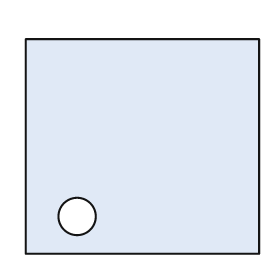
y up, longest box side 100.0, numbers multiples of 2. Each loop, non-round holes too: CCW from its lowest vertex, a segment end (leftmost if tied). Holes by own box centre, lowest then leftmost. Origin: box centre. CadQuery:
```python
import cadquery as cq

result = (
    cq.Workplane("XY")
    .moveTo(-50.0, -46.0)
    .lineTo(50.0, -46.0)
    .lineTo(50.0, 46.0)
    .lineTo(-50.0, 46.0)
    .close()
    .moveTo(-28.0, -30.0)
    .circle(8.0)
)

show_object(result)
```